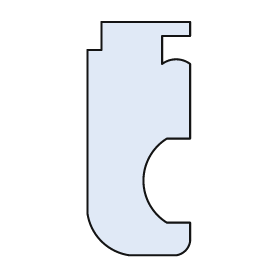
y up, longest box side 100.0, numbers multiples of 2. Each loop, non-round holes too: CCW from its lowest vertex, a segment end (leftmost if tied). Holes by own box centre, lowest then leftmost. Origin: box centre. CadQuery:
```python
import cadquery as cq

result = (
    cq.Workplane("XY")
    .moveTo(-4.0, -50.0)
    .lineTo(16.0, -50.0)
    .threePointArc((20.0, -48.0), (22.0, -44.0))
    .lineTo(22.0, -36.0)
    .lineTo(12.0, -36.0)
    .threePointArc((2.0, -18.0), (12.0, 0.0))
    .lineTo(22.0, 0.0)
    .lineTo(22.0, 32.0)
    .threePointArc((16.0, 34.0), (10.0, 32.0))
    .lineTo(10.0, 44.0)
    .lineTo(22.0, 44.0)
    .lineTo(22.0, 50.0)
    .lineTo(-16.0, 50.0)
    .lineTo(-16.0, 38.0)
    .lineTo(-22.0, 38.0)
    .lineTo(-22.0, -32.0)
    .threePointArc((-16.0, -44.0), (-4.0, -50.0))
    .close()
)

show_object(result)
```